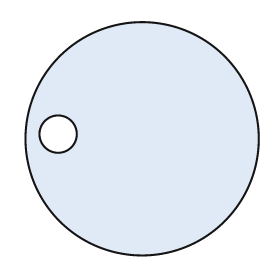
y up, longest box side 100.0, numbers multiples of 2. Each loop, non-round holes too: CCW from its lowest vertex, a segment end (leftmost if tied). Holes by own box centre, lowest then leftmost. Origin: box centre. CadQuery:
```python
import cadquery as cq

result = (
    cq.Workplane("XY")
    .moveTo(0.0, 0.0)
    .circle(50.0)
    .moveTo(-36.0, 2.0)
    .circle(8.0)
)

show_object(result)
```